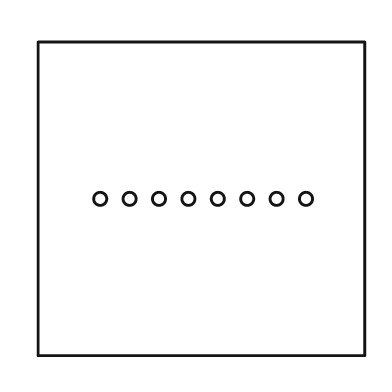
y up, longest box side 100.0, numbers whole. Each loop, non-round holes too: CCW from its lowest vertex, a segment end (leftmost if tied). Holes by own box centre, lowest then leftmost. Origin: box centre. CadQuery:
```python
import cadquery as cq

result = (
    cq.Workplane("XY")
    .moveTo(-50.0, -48.0)
    .lineTo(50.0, -48.0)
    .lineTo(50.0, 48.0)
    .lineTo(-50.0, 48.0)
    .close()
    .moveTo(-31.0, 0.0)
    .circle(2.0)
    .moveTo(-22.0, 0.0)
    .circle(2.0)
    .moveTo(-13.0, 0.0)
    .circle(2.0)
    .moveTo(-4.0, 0.0)
    .circle(2.0)
    .moveTo(5.0, 0.0)
    .circle(2.0)
    .moveTo(14.0, 0.0)
    .circle(2.0)
    .moveTo(23.0, 0.0)
    .circle(2.0)
    .moveTo(32.0, 0.0)
    .circle(2.0)
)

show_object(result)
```